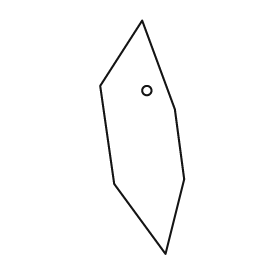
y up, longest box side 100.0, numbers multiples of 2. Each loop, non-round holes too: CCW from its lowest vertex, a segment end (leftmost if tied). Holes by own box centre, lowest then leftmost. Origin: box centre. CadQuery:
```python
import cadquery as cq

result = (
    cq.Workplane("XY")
    .moveTo(10.0, -50.0)
    .lineTo(18.0, -18.0)
    .lineTo(14.0, 12.0)
    .lineTo(0.0, 50.0)
    .lineTo(-18.0, 22.0)
    .lineTo(-12.0, -20.0)
    .close()
    .moveTo(2.0, 20.0)
    .circle(2.0)
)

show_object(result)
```